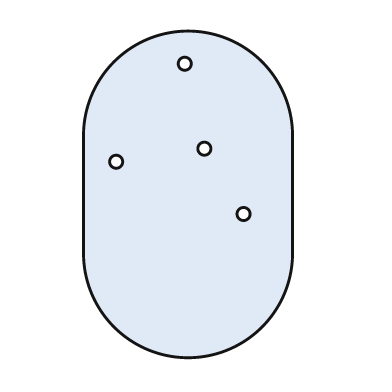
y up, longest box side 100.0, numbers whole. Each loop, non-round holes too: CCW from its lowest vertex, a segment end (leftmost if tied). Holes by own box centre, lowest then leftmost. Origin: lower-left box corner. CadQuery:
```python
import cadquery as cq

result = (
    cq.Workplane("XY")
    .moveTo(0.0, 32.0)
    .threePointArc((32.0, 0.0), (64.0, 32.0))
    .lineTo(64.0, 68.0)
    .threePointArc((32.0, 100.0), (0.0, 68.0))
    .close()
    .moveTo(49.0, 44.0)
    .circle(2.0)
    .moveTo(10.0, 60.0)
    .circle(2.0)
    .moveTo(37.0, 64.0)
    .circle(2.0)
    .moveTo(31.0, 90.0)
    .circle(2.0)
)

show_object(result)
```